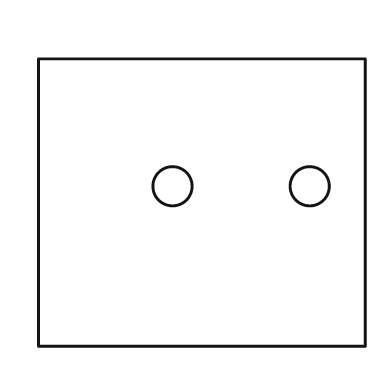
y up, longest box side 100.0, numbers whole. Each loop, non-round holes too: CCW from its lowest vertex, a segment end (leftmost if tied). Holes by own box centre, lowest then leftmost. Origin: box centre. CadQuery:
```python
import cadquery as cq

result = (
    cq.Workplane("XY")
    .moveTo(-50.0, -44.0)
    .lineTo(50.0, -44.0)
    .lineTo(50.0, 44.0)
    .lineTo(-50.0, 44.0)
    .close()
    .moveTo(-9.0, 5.0)
    .circle(6.0)
    .moveTo(33.0, 5.0)
    .circle(6.0)
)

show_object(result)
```